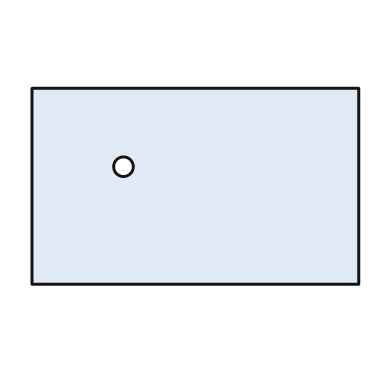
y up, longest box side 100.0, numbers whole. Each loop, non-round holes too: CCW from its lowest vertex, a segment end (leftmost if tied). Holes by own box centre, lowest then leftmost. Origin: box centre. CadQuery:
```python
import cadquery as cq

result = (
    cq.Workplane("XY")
    .moveTo(-50.0, -30.0)
    .lineTo(50.0, -30.0)
    .lineTo(50.0, 30.0)
    .lineTo(-50.0, 30.0)
    .close()
    .moveTo(-22.0, 6.0)
    .circle(3.0)
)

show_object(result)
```